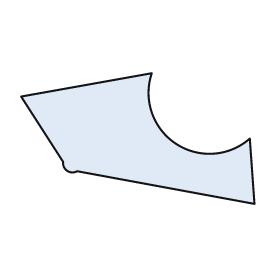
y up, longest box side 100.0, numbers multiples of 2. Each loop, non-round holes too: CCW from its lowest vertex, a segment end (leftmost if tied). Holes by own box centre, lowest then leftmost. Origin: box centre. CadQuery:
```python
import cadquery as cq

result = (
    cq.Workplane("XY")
    .moveTo(50.0, -28.0)
    .lineTo(48.0, 0.0)
    .threePointArc((16.0, -2.0), (6.0, 28.0))
    .lineTo(-50.0, 18.0)
    .lineTo(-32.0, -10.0)
    .threePointArc((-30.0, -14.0), (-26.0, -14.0))
    .close()
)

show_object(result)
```